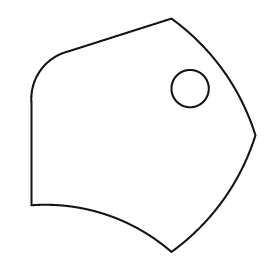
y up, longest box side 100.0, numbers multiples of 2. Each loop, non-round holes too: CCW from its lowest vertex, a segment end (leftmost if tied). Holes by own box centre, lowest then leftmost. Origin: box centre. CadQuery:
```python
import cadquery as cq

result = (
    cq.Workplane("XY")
    .moveTo(12.0, -50.0)
    .threePointArc((34.0, -28.0), (48.0, 0.0))
    .threePointArc((34.0, 28.0), (12.0, 50.0))
    .lineTo(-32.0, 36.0)
    .threePointArc((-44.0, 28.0), (-48.0, 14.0))
    .lineTo(-48.0, -30.0)
    .threePointArc((-16.0, -34.0), (12.0, -50.0))
    .close()
    .moveTo(20.0, 20.0)
    .circle(8.0)
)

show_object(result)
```